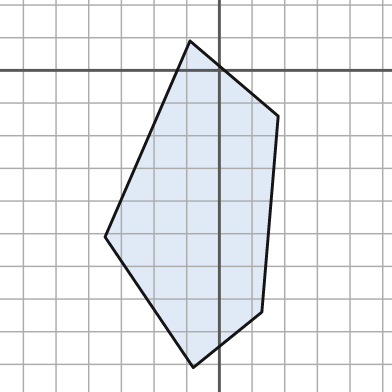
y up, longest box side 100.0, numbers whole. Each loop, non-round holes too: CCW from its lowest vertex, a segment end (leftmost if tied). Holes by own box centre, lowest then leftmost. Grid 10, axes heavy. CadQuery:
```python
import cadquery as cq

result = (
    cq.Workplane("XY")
    .moveTo(-8.0, -91.0)
    .lineTo(13.0, -74.0)
    .lineTo(18.0, -14.0)
    .lineTo(-9.0, 9.0)
    .lineTo(-35.0, -51.0)
    .close()
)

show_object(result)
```